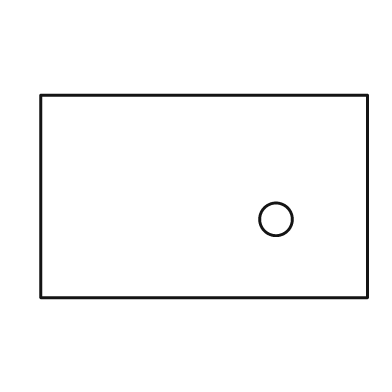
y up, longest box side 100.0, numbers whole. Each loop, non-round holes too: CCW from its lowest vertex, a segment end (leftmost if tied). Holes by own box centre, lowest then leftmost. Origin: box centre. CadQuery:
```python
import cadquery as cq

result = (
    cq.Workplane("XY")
    .moveTo(-50.0, -31.0)
    .lineTo(50.0, -31.0)
    .lineTo(50.0, 31.0)
    .lineTo(-50.0, 31.0)
    .close()
    .moveTo(22.0, -7.0)
    .circle(5.0)
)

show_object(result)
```